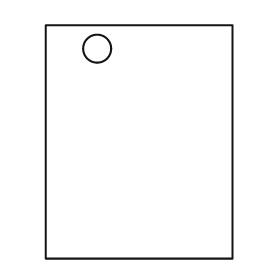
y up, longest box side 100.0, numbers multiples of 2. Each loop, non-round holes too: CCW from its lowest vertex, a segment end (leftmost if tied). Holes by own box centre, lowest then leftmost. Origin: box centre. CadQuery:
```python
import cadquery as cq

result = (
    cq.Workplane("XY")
    .moveTo(-40.0, -50.0)
    .lineTo(40.0, -50.0)
    .lineTo(40.0, 50.0)
    .lineTo(-40.0, 50.0)
    .close()
    .moveTo(-18.0, 40.0)
    .circle(6.0)
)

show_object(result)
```